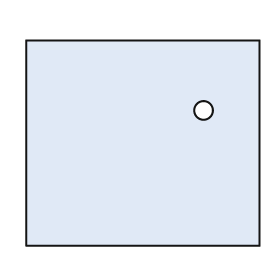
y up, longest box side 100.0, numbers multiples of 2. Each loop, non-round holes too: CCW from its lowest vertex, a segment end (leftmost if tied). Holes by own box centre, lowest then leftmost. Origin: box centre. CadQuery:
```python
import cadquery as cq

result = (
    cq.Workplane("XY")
    .moveTo(-50.0, -44.0)
    .lineTo(50.0, -44.0)
    .lineTo(50.0, 44.0)
    .lineTo(-50.0, 44.0)
    .close()
    .moveTo(26.0, 14.0)
    .circle(4.0)
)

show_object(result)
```